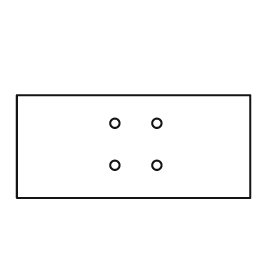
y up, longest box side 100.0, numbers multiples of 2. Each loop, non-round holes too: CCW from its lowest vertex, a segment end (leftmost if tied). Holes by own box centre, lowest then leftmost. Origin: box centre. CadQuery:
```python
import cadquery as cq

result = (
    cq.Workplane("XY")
    .moveTo(-50.0, -22.0)
    .lineTo(50.0, -22.0)
    .lineTo(50.0, 22.0)
    .lineTo(-50.0, 22.0)
    .close()
    .moveTo(-8.0, -8.0)
    .circle(2.0)
    .moveTo(10.0, -8.0)
    .circle(2.0)
    .moveTo(-8.0, 10.0)
    .circle(2.0)
    .moveTo(10.0, 10.0)
    .circle(2.0)
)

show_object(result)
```